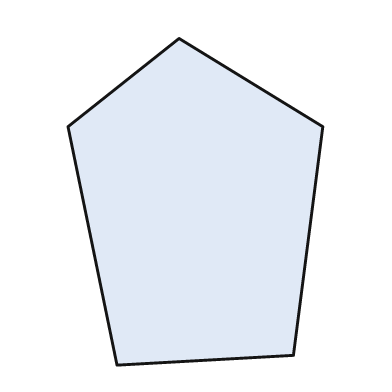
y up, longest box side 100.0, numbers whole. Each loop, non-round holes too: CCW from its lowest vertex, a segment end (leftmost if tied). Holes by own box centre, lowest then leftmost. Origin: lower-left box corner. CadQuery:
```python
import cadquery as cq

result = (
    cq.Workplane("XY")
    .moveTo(15.0, 0.0)
    .lineTo(69.0, 3.0)
    .lineTo(78.0, 73.0)
    .lineTo(34.0, 100.0)
    .lineTo(0.0, 73.0)
    .close()
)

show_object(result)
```